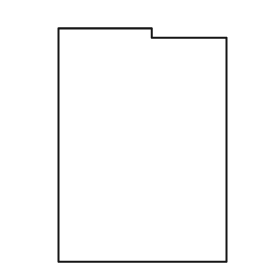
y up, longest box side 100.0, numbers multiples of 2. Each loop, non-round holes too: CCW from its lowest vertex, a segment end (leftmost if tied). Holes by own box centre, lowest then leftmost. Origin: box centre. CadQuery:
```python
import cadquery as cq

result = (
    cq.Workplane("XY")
    .moveTo(-36.0, -50.0)
    .lineTo(36.0, -50.0)
    .lineTo(36.0, 46.0)
    .lineTo(4.0, 46.0)
    .lineTo(4.0, 50.0)
    .lineTo(-36.0, 50.0)
    .close()
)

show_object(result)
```